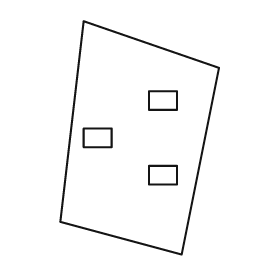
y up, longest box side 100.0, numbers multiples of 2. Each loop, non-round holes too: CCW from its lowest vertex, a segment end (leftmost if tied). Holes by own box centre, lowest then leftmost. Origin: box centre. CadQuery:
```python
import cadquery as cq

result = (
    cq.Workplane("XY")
    .moveTo(18.0, -50.0)
    .lineTo(34.0, 30.0)
    .lineTo(-24.0, 50.0)
    .lineTo(-34.0, -36.0)
    .close()
    .moveTo(4.0, -20.0)
    .lineTo(16.0, -20.0)
    .lineTo(16.0, -12.0)
    .lineTo(4.0, -12.0)
    .close()
    .moveTo(-24.0, -4.0)
    .lineTo(-12.0, -4.0)
    .lineTo(-12.0, 4.0)
    .lineTo(-24.0, 4.0)
    .close()
    .moveTo(4.0, 12.0)
    .lineTo(16.0, 12.0)
    .lineTo(16.0, 20.0)
    .lineTo(4.0, 20.0)
    .close()
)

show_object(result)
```